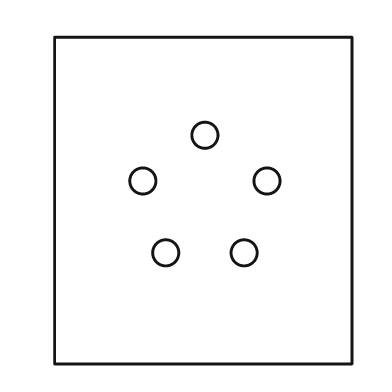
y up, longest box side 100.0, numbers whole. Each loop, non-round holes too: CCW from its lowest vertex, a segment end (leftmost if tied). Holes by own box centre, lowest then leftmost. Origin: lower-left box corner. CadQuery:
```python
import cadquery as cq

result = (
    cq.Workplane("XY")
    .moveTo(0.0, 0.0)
    .lineTo(91.0, 0.0)
    .lineTo(91.0, 100.0)
    .lineTo(0.0, 100.0)
    .close()
    .moveTo(34.0, 34.0)
    .circle(4.0)
    .moveTo(58.0, 34.0)
    .circle(4.0)
    .moveTo(27.0, 56.0)
    .circle(4.0)
    .moveTo(65.0, 56.0)
    .circle(4.0)
    .moveTo(46.0, 70.0)
    .circle(4.0)
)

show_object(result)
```